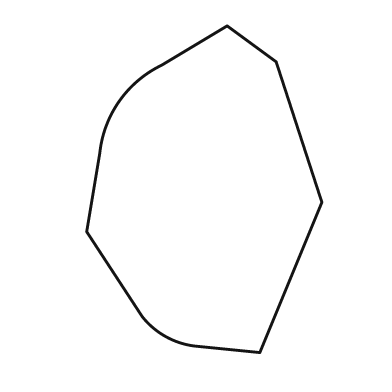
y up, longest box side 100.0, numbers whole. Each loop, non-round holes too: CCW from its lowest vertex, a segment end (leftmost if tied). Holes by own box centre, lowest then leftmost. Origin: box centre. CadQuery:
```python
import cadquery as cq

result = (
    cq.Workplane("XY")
    .moveTo(17.0, -50.0)
    .lineTo(36.0, -4.0)
    .lineTo(22.0, 39.0)
    .lineTo(7.0, 50.0)
    .lineTo(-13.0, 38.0)
    .threePointArc((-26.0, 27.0), (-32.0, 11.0))
    .lineTo(-36.0, -13.0)
    .lineTo(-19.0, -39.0)
    .threePointArc((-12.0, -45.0), (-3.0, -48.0))
    .close()
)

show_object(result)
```